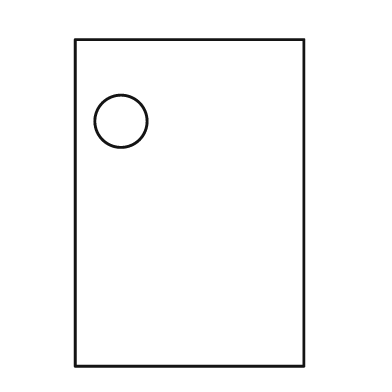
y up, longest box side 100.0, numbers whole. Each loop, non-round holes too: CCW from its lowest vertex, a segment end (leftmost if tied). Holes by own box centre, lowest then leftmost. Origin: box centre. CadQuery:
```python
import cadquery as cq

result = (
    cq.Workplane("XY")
    .moveTo(-35.0, -50.0)
    .lineTo(35.0, -50.0)
    .lineTo(35.0, 50.0)
    .lineTo(-35.0, 50.0)
    .close()
    .moveTo(-21.0, 25.0)
    .circle(8.0)
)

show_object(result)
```